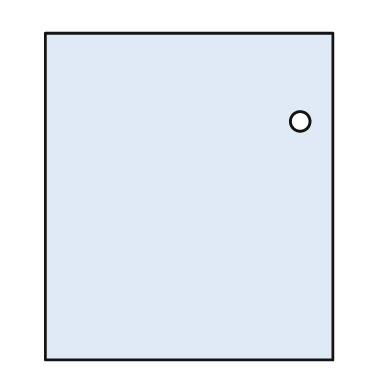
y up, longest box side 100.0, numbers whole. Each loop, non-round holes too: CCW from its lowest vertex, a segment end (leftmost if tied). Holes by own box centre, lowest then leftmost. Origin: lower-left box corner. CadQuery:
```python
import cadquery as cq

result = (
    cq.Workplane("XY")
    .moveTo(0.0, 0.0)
    .lineTo(88.0, 0.0)
    .lineTo(88.0, 100.0)
    .lineTo(0.0, 100.0)
    .close()
    .moveTo(78.0, 73.0)
    .circle(3.0)
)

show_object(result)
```